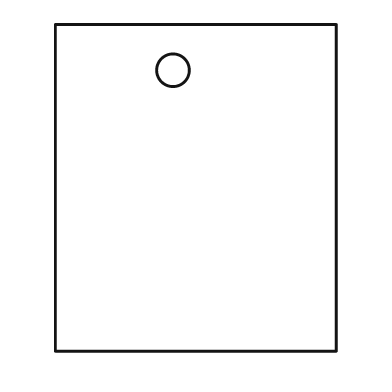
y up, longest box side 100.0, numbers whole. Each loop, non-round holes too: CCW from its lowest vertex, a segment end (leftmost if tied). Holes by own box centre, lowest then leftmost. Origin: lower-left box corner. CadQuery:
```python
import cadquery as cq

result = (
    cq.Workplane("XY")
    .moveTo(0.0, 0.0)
    .lineTo(86.0, 0.0)
    .lineTo(86.0, 100.0)
    .lineTo(0.0, 100.0)
    .close()
    .moveTo(36.0, 86.0)
    .circle(5.0)
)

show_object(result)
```